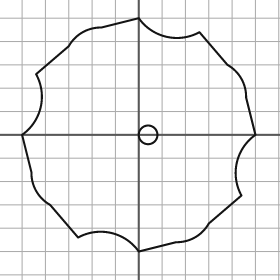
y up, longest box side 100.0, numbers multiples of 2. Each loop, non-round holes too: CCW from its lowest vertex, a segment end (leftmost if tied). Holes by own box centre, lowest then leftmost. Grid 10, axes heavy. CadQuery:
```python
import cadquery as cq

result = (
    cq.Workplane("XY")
    .moveTo(0.0, -50.0)
    .lineTo(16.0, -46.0)
    .threePointArc((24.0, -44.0), (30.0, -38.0))
    .lineTo(44.0, -26.0)
    .threePointArc((42.0, -12.0), (50.0, 0.0))
    .lineTo(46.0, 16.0)
    .threePointArc((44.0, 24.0), (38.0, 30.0))
    .lineTo(26.0, 44.0)
    .threePointArc((12.0, 42.0), (0.0, 50.0))
    .lineTo(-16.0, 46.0)
    .threePointArc((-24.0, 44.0), (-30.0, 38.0))
    .lineTo(-44.0, 26.0)
    .threePointArc((-42.0, 12.0), (-50.0, 0.0))
    .lineTo(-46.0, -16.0)
    .threePointArc((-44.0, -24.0), (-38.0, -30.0))
    .lineTo(-26.0, -44.0)
    .threePointArc((-12.0, -42.0), (0.0, -50.0))
    .close()
    .moveTo(4.0, 0.0)
    .circle(4.0)
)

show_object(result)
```